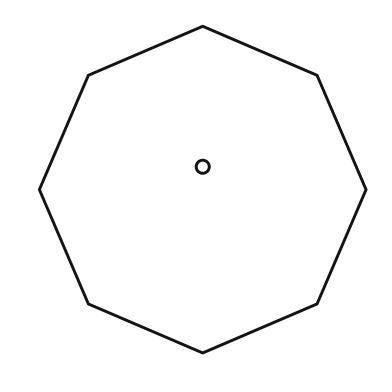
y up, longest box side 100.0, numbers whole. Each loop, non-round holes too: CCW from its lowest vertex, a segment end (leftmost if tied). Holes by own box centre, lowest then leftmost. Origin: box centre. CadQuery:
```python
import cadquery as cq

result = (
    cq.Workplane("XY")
    .moveTo(0.0, -50.0)
    .lineTo(35.0, -35.0)
    .lineTo(50.0, 0.0)
    .lineTo(35.0, 35.0)
    .lineTo(0.0, 50.0)
    .lineTo(-35.0, 35.0)
    .lineTo(-50.0, 0.0)
    .lineTo(-35.0, -35.0)
    .close()
    .moveTo(0.0, 7.0)
    .circle(2.0)
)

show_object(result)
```